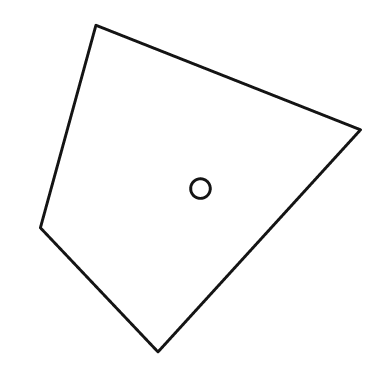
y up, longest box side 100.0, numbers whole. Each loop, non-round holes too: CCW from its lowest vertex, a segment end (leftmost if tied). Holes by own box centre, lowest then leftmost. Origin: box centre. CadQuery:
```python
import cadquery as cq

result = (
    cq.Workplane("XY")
    .moveTo(-13.0, -50.0)
    .lineTo(49.0, 18.0)
    .lineTo(-32.0, 50.0)
    .lineTo(-49.0, -12.0)
    .close()
    .moveTo(0.0, 0.0)
    .circle(3.0)
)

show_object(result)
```